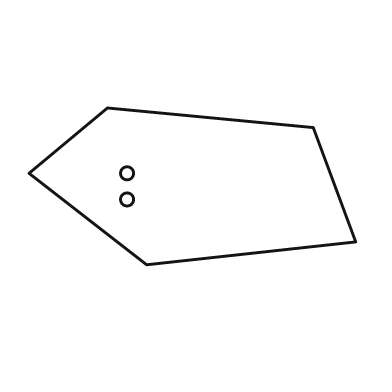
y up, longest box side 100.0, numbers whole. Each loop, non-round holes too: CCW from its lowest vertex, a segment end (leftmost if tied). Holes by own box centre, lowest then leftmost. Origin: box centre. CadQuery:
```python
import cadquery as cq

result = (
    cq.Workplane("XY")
    .moveTo(-14.0, -24.0)
    .lineTo(50.0, -17.0)
    .lineTo(37.0, 18.0)
    .lineTo(-26.0, 24.0)
    .lineTo(-50.0, 4.0)
    .close()
    .moveTo(-20.0, -4.0)
    .circle(2.0)
    .moveTo(-20.0, 4.0)
    .circle(2.0)
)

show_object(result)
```